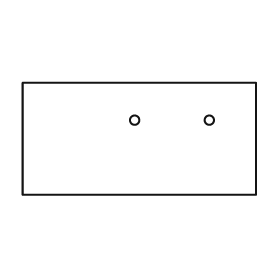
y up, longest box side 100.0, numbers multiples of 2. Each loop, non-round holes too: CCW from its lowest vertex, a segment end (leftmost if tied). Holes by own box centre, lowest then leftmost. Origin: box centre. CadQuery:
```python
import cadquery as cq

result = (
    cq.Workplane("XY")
    .moveTo(-50.0, -24.0)
    .lineTo(50.0, -24.0)
    .lineTo(50.0, 24.0)
    .lineTo(-50.0, 24.0)
    .close()
    .moveTo(-2.0, 8.0)
    .circle(2.0)
    .moveTo(30.0, 8.0)
    .circle(2.0)
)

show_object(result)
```